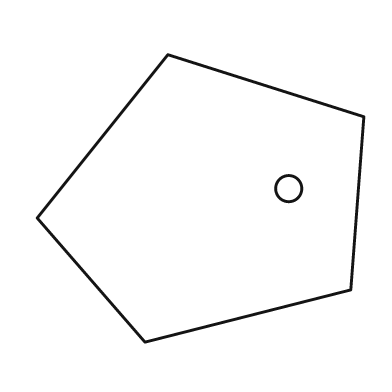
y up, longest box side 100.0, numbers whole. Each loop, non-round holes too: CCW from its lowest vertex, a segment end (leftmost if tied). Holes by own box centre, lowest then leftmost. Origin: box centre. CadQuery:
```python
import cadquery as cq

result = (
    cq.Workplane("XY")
    .moveTo(-17.0, -44.0)
    .lineTo(46.0, -28.0)
    .lineTo(50.0, 25.0)
    .lineTo(-10.0, 44.0)
    .lineTo(-50.0, -6.0)
    .close()
    .moveTo(27.0, 3.0)
    .circle(4.0)
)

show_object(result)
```